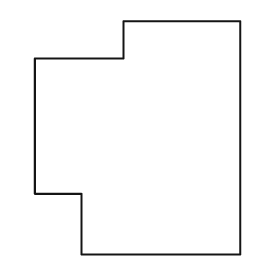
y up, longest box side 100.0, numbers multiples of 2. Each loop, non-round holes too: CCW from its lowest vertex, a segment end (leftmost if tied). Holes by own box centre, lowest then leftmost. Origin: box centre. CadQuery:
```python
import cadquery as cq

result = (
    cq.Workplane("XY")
    .moveTo(-24.0, -50.0)
    .lineTo(44.0, -50.0)
    .lineTo(44.0, 50.0)
    .lineTo(-6.0, 50.0)
    .lineTo(-6.0, 34.0)
    .lineTo(-44.0, 34.0)
    .lineTo(-44.0, -24.0)
    .lineTo(-24.0, -24.0)
    .close()
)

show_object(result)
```